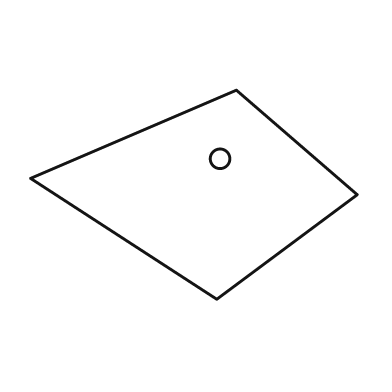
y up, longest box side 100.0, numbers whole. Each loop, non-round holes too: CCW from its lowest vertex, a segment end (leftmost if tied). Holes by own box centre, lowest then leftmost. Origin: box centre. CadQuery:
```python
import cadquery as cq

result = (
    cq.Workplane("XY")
    .moveTo(7.0, -32.0)
    .lineTo(50.0, 0.0)
    .lineTo(13.0, 32.0)
    .lineTo(-50.0, 5.0)
    .close()
    .moveTo(8.0, 11.0)
    .circle(3.0)
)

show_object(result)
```